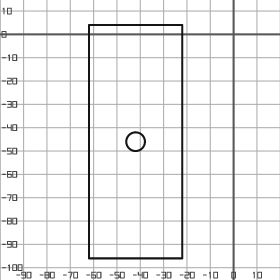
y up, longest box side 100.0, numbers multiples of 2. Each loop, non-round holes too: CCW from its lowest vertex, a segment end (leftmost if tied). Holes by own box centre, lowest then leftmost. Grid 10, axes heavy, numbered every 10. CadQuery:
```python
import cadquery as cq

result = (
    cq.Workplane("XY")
    .moveTo(-62.0, -96.0)
    .lineTo(-22.0, -96.0)
    .lineTo(-22.0, 4.0)
    .lineTo(-62.0, 4.0)
    .close()
    .moveTo(-42.0, -46.0)
    .circle(4.0)
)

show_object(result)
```